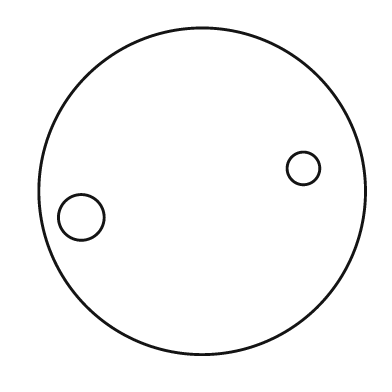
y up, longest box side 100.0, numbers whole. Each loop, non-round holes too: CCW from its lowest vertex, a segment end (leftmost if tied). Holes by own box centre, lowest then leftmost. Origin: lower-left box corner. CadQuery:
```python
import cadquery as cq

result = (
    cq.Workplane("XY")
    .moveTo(50.0, 50.0)
    .circle(50.0)
    .moveTo(13.0, 42.0)
    .circle(7.0)
    .moveTo(81.0, 57.0)
    .circle(5.0)
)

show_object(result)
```